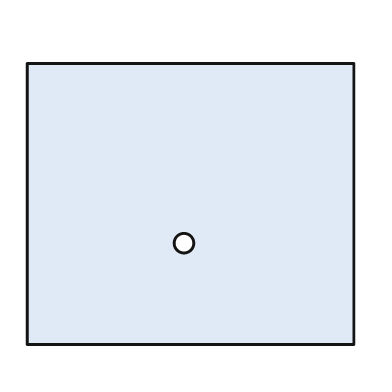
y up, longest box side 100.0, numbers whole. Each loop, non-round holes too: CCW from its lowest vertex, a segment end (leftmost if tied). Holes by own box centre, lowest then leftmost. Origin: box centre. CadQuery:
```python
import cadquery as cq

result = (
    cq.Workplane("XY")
    .moveTo(-50.0, -43.0)
    .lineTo(50.0, -43.0)
    .lineTo(50.0, 43.0)
    .lineTo(-50.0, 43.0)
    .close()
    .moveTo(-2.0, -12.0)
    .circle(3.0)
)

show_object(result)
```